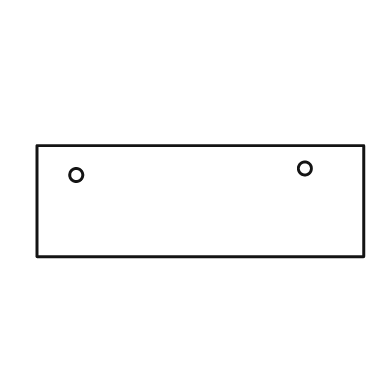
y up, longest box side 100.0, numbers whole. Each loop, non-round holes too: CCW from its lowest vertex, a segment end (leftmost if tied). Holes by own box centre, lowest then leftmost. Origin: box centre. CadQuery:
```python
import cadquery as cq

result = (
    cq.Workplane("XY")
    .moveTo(-50.0, -17.0)
    .lineTo(50.0, -17.0)
    .lineTo(50.0, 17.0)
    .lineTo(-50.0, 17.0)
    .close()
    .moveTo(-38.0, 8.0)
    .circle(2.0)
    .moveTo(32.0, 10.0)
    .circle(2.0)
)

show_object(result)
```